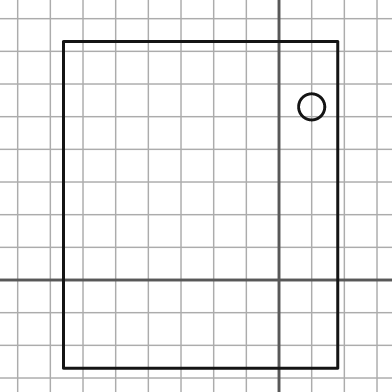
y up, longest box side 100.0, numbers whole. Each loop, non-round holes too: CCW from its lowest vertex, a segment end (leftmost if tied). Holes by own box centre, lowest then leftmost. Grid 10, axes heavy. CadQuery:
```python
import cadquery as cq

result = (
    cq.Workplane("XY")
    .moveTo(-66.0, -27.0)
    .lineTo(18.0, -27.0)
    .lineTo(18.0, 73.0)
    .lineTo(-66.0, 73.0)
    .close()
    .moveTo(10.0, 53.0)
    .circle(4.0)
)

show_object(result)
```